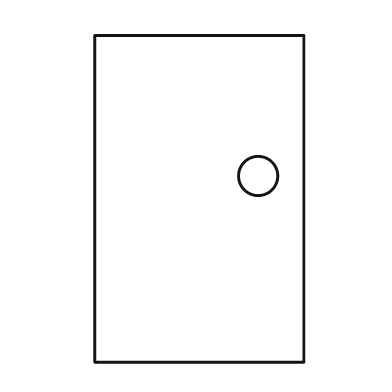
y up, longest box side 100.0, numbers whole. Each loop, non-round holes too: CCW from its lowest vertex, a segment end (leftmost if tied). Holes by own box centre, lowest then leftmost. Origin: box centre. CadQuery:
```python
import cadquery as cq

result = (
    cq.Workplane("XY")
    .moveTo(-32.0, -50.0)
    .lineTo(32.0, -50.0)
    .lineTo(32.0, 50.0)
    .lineTo(-32.0, 50.0)
    .close()
    .moveTo(18.0, 7.0)
    .circle(6.0)
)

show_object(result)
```